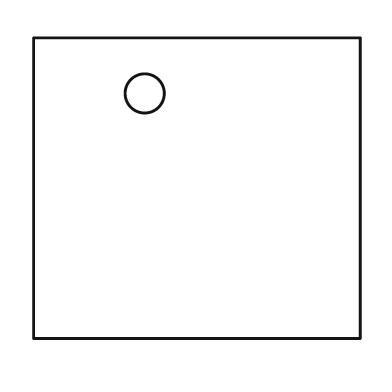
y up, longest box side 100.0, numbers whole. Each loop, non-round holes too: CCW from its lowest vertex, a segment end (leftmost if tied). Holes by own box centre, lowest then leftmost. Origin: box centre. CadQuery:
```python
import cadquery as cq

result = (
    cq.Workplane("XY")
    .moveTo(-50.0, -46.0)
    .lineTo(50.0, -46.0)
    .lineTo(50.0, 46.0)
    .lineTo(-50.0, 46.0)
    .close()
    .moveTo(-16.0, 29.0)
    .circle(6.0)
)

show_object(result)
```